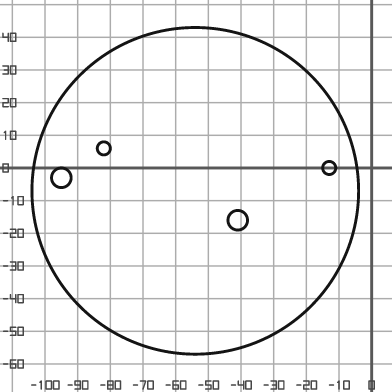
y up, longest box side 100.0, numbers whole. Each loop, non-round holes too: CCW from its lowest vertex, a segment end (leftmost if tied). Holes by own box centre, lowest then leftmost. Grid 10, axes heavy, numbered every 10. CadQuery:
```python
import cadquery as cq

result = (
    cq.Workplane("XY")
    .moveTo(-54.0, -7.0)
    .circle(50.0)
    .moveTo(-41.0, -16.0)
    .circle(3.0)
    .moveTo(-95.0, -3.0)
    .circle(3.0)
    .moveTo(-13.0, 0.0)
    .circle(2.0)
    .moveTo(-82.0, 6.0)
    .circle(2.0)
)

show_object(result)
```